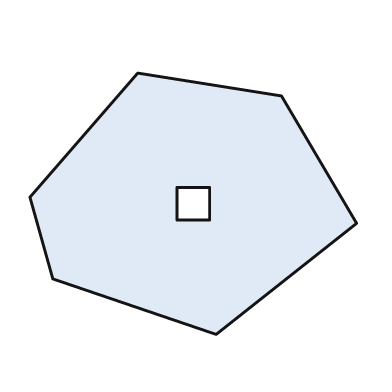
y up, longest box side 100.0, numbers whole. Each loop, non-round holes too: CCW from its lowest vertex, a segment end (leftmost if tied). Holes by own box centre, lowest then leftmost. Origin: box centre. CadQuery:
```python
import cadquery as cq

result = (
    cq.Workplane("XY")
    .moveTo(7.0, -40.0)
    .lineTo(50.0, -6.0)
    .lineTo(27.0, 33.0)
    .lineTo(-17.0, 40.0)
    .lineTo(-50.0, 2.0)
    .lineTo(-43.0, -23.0)
    .close()
    .moveTo(-5.0, -5.0)
    .lineTo(5.0, -5.0)
    .lineTo(5.0, 5.0)
    .lineTo(-5.0, 5.0)
    .close()
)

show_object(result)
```